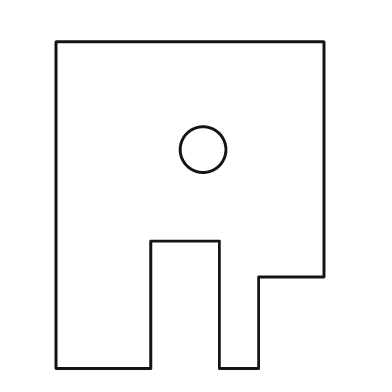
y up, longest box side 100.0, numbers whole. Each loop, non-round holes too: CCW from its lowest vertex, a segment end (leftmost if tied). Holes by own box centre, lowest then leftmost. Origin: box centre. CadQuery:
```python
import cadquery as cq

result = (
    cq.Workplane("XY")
    .moveTo(-41.0, -50.0)
    .lineTo(-12.0, -50.0)
    .lineTo(-12.0, -11.0)
    .lineTo(9.0, -11.0)
    .lineTo(9.0, -50.0)
    .lineTo(21.0, -50.0)
    .lineTo(21.0, -22.0)
    .lineTo(41.0, -22.0)
    .lineTo(41.0, 50.0)
    .lineTo(-41.0, 50.0)
    .close()
    .moveTo(4.0, 17.0)
    .circle(7.0)
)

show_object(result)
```